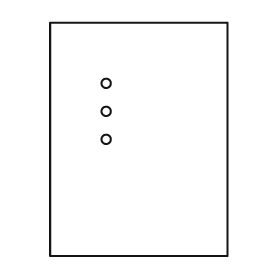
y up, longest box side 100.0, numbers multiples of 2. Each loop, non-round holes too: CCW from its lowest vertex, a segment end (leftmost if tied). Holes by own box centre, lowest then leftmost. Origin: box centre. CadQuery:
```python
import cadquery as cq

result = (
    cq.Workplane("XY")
    .moveTo(-38.0, -50.0)
    .lineTo(38.0, -50.0)
    .lineTo(38.0, 50.0)
    .lineTo(-38.0, 50.0)
    .close()
    .moveTo(-14.0, 0.0)
    .circle(2.0)
    .moveTo(-14.0, 12.0)
    .circle(2.0)
    .moveTo(-14.0, 24.0)
    .circle(2.0)
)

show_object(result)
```